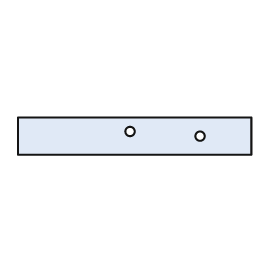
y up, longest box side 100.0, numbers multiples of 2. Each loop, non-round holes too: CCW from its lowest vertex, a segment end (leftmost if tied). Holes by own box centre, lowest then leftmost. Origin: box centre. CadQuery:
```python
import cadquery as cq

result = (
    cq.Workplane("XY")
    .moveTo(-50.0, -8.0)
    .lineTo(50.0, -8.0)
    .lineTo(50.0, 8.0)
    .lineTo(-50.0, 8.0)
    .close()
    .moveTo(28.0, 0.0)
    .circle(2.0)
    .moveTo(-2.0, 2.0)
    .circle(2.0)
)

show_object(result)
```